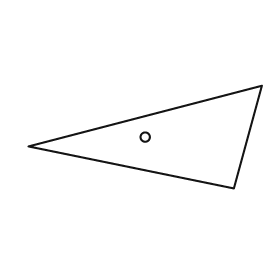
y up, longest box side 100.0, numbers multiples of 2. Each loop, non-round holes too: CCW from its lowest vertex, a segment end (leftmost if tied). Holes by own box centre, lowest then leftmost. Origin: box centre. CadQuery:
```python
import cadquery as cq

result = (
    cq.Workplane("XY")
    .moveTo(38.0, -22.0)
    .lineTo(50.0, 22.0)
    .lineTo(-50.0, -4.0)
    .close()
    .moveTo(0.0, 0.0)
    .circle(2.0)
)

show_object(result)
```